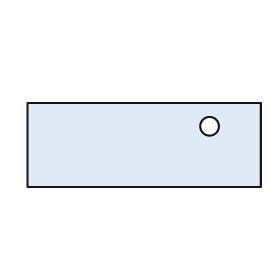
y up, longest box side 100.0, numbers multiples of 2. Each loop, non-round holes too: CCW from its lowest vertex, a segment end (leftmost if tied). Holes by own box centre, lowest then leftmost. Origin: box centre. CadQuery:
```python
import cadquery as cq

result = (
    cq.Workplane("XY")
    .moveTo(-50.0, -18.0)
    .lineTo(50.0, -18.0)
    .lineTo(50.0, 18.0)
    .lineTo(-50.0, 18.0)
    .close()
    .moveTo(28.0, 8.0)
    .circle(4.0)
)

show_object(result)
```